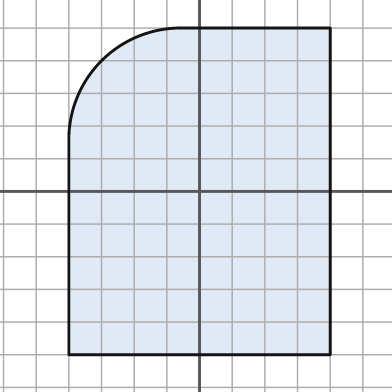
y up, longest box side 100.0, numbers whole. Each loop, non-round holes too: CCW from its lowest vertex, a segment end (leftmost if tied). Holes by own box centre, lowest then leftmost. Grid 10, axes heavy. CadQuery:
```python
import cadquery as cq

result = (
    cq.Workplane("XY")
    .moveTo(-40.0, -50.0)
    .lineTo(40.0, -50.0)
    .lineTo(40.0, 50.0)
    .lineTo(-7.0, 50.0)
    .threePointArc((-30.0, 40.0), (-40.0, 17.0))
    .close()
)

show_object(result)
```